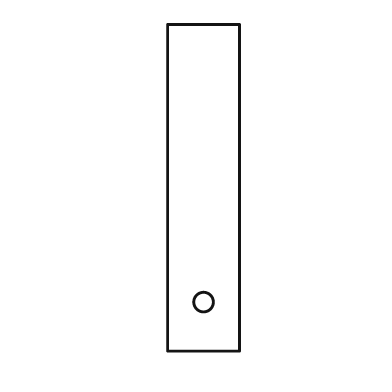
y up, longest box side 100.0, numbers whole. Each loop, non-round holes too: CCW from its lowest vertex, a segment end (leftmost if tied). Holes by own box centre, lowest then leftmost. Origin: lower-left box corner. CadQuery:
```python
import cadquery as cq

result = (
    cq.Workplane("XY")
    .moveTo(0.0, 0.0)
    .lineTo(22.0, 0.0)
    .lineTo(22.0, 100.0)
    .lineTo(0.0, 100.0)
    .close()
    .moveTo(11.0, 15.0)
    .circle(3.0)
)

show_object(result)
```